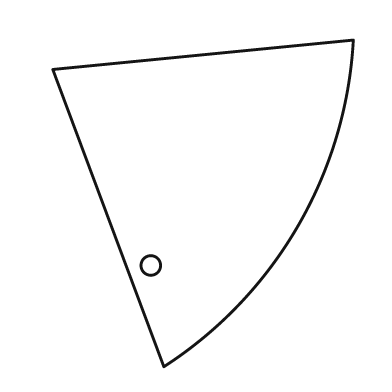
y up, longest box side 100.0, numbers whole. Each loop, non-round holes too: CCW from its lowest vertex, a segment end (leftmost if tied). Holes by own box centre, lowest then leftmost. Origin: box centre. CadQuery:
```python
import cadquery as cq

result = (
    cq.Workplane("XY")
    .moveTo(-12.0, -50.0)
    .threePointArc((29.0, -7.0), (46.0, 50.0))
    .lineTo(-46.0, 41.0)
    .close()
    .moveTo(-16.0, -19.0)
    .circle(3.0)
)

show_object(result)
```